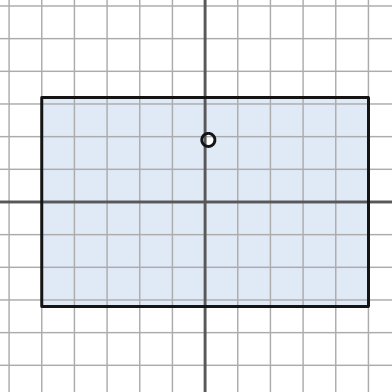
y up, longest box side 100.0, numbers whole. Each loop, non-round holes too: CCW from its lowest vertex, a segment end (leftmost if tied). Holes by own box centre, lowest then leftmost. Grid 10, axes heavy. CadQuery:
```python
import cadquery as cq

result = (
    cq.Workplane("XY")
    .moveTo(-50.0, -32.0)
    .lineTo(50.0, -32.0)
    .lineTo(50.0, 32.0)
    .lineTo(-50.0, 32.0)
    .close()
    .moveTo(1.0, 19.0)
    .circle(2.0)
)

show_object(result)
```